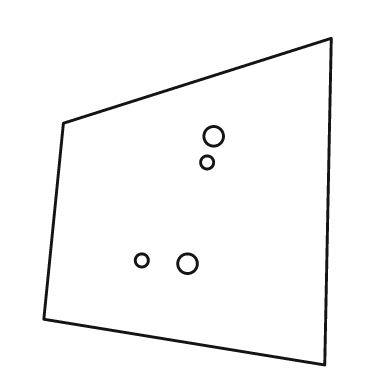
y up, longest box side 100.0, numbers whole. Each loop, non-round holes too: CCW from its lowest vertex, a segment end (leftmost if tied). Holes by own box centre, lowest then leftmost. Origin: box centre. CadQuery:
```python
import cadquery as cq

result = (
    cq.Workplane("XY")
    .moveTo(42.0, -50.0)
    .lineTo(44.0, 50.0)
    .lineTo(-38.0, 24.0)
    .lineTo(-44.0, -36.0)
    .close()
    .moveTo(0.0, -19.0)
    .circle(3.0)
    .moveTo(-14.0, -18.0)
    .circle(2.0)
    .moveTo(6.0, 12.0)
    .circle(2.0)
    .moveTo(8.0, 20.0)
    .circle(3.0)
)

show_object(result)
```